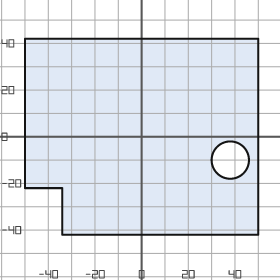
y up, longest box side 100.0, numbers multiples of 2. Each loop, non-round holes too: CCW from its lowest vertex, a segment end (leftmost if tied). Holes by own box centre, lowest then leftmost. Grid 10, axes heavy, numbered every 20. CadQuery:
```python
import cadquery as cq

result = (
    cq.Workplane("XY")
    .moveTo(-34.0, -42.0)
    .lineTo(50.0, -42.0)
    .lineTo(50.0, 42.0)
    .lineTo(-50.0, 42.0)
    .lineTo(-50.0, -22.0)
    .lineTo(-34.0, -22.0)
    .close()
    .moveTo(38.0, -10.0)
    .circle(8.0)
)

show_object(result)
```